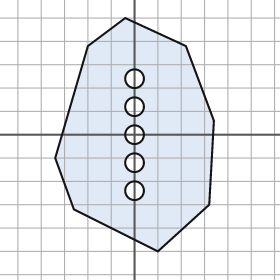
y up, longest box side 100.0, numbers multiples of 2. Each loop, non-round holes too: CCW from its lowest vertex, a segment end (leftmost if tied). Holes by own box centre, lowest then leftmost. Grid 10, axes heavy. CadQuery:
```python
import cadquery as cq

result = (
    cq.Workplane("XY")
    .moveTo(10.0, -50.0)
    .lineTo(32.0, -30.0)
    .lineTo(34.0, 6.0)
    .lineTo(22.0, 38.0)
    .lineTo(-4.0, 50.0)
    .lineTo(-20.0, 38.0)
    .lineTo(-34.0, -10.0)
    .lineTo(-26.0, -32.0)
    .close()
    .moveTo(0.0, -24.0)
    .circle(4.0)
    .moveTo(0.0, -12.0)
    .circle(4.0)
    .moveTo(0.0, 0.0)
    .circle(4.0)
    .moveTo(0.0, 12.0)
    .circle(4.0)
    .moveTo(0.0, 24.0)
    .circle(4.0)
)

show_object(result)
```